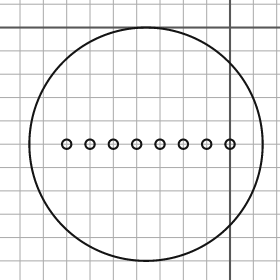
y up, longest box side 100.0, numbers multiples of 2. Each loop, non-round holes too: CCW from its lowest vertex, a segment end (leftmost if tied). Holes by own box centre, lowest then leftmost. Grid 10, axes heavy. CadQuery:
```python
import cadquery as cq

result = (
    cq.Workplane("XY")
    .moveTo(-36.0, -50.0)
    .circle(50.0)
    .moveTo(-70.0, -50.0)
    .circle(2.0)
    .moveTo(-60.0, -50.0)
    .circle(2.0)
    .moveTo(-50.0, -50.0)
    .circle(2.0)
    .moveTo(-40.0, -50.0)
    .circle(2.0)
    .moveTo(-30.0, -50.0)
    .circle(2.0)
    .moveTo(-20.0, -50.0)
    .circle(2.0)
    .moveTo(-10.0, -50.0)
    .circle(2.0)
    .moveTo(0.0, -50.0)
    .circle(2.0)
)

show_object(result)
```